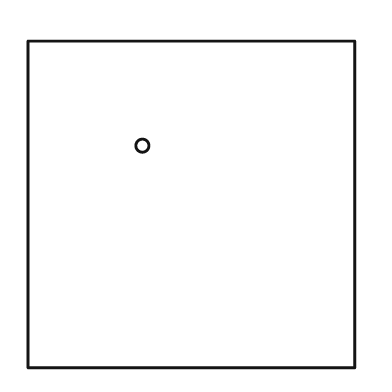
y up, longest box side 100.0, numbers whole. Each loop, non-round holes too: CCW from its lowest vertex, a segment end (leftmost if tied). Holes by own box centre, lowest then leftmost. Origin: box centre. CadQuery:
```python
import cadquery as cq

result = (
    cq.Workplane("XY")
    .moveTo(-50.0, -50.0)
    .lineTo(50.0, -50.0)
    .lineTo(50.0, 50.0)
    .lineTo(-50.0, 50.0)
    .close()
    .moveTo(-15.0, 18.0)
    .circle(2.0)
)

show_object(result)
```